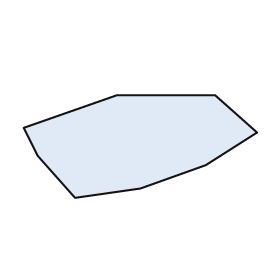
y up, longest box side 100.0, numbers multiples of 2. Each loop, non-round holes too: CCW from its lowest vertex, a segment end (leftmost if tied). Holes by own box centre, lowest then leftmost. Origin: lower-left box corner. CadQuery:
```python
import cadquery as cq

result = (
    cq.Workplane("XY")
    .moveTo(22.0, 0.0)
    .lineTo(50.0, 4.0)
    .lineTo(78.0, 14.0)
    .lineTo(100.0, 28.0)
    .lineTo(82.0, 44.0)
    .lineTo(40.0, 44.0)
    .lineTo(0.0, 30.0)
    .lineTo(6.0, 18.0)
    .close()
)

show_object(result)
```